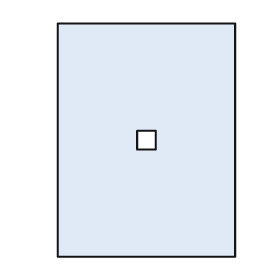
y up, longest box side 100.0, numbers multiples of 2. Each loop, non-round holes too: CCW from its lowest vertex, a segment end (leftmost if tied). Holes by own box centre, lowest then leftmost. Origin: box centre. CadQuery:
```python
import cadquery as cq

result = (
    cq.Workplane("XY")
    .moveTo(-38.0, -50.0)
    .lineTo(38.0, -50.0)
    .lineTo(38.0, 50.0)
    .lineTo(-38.0, 50.0)
    .close()
    .moveTo(-4.0, -4.0)
    .lineTo(4.0, -4.0)
    .lineTo(4.0, 4.0)
    .lineTo(-4.0, 4.0)
    .close()
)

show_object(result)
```